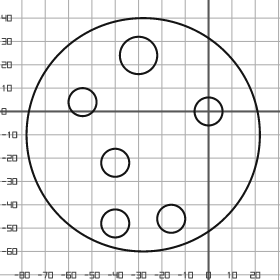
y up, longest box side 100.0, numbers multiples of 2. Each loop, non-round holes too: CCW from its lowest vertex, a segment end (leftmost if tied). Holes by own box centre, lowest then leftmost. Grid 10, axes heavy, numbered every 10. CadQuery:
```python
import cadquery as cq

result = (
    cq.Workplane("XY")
    .moveTo(-28.0, -10.0)
    .circle(50.0)
    .moveTo(-40.0, -48.0)
    .circle(6.0)
    .moveTo(-16.0, -46.0)
    .circle(6.0)
    .moveTo(-40.0, -22.0)
    .circle(6.0)
    .moveTo(0.0, 0.0)
    .circle(6.0)
    .moveTo(-54.0, 4.0)
    .circle(6.0)
    .moveTo(-30.0, 24.0)
    .circle(8.0)
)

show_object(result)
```